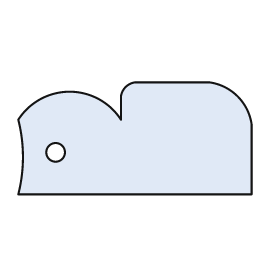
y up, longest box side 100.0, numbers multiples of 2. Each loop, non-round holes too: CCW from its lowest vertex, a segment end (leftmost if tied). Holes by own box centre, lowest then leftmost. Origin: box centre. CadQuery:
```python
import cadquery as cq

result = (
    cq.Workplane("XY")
    .moveTo(-50.0, -24.0)
    .lineTo(50.0, -24.0)
    .lineTo(50.0, 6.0)
    .threePointArc((44.0, 18.0), (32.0, 24.0))
    .lineTo(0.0, 24.0)
    .threePointArc((-4.0, 22.0), (-6.0, 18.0))
    .lineTo(-6.0, 8.0)
    .threePointArc((-28.0, 20.0), (-50.0, 8.0))
    .threePointArc((-48.0, -8.0), (-50.0, -24.0))
    .close()
    .moveTo(-34.0, -6.0)
    .circle(4.0)
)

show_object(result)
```